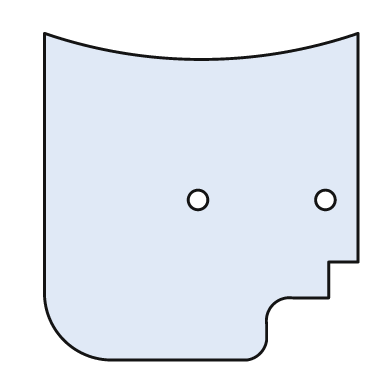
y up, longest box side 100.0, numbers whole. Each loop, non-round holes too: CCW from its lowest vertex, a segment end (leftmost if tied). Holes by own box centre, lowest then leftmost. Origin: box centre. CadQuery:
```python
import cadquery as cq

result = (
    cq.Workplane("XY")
    .moveTo(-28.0, -50.0)
    .lineTo(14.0, -50.0)
    .threePointArc((18.0, -48.0), (20.0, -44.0))
    .lineTo(20.0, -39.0)
    .threePointArc((22.0, -33.0), (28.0, -31.0))
    .lineTo(39.0, -31.0)
    .lineTo(39.0, -20.0)
    .lineTo(48.0, -20.0)
    .lineTo(48.0, 50.0)
    .threePointArc((0.0, 42.0), (-48.0, 50.0))
    .lineTo(-48.0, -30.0)
    .threePointArc((-42.0, -44.0), (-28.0, -50.0))
    .close()
    .moveTo(-1.0, -1.0)
    .circle(3.0)
    .moveTo(38.0, -1.0)
    .circle(3.0)
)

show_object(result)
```